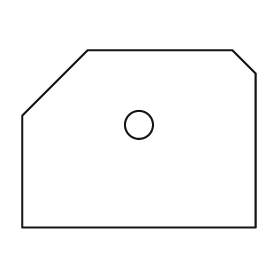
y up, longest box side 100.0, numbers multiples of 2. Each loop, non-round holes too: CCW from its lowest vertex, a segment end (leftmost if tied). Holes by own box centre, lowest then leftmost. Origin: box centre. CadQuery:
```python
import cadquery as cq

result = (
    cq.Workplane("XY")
    .moveTo(-50.0, -38.0)
    .lineTo(50.0, -38.0)
    .lineTo(50.0, 28.0)
    .lineTo(40.0, 38.0)
    .lineTo(-22.0, 38.0)
    .lineTo(-50.0, 10.0)
    .close()
    .moveTo(0.0, 6.0)
    .circle(6.0)
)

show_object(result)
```